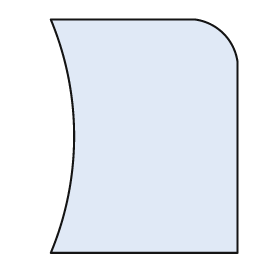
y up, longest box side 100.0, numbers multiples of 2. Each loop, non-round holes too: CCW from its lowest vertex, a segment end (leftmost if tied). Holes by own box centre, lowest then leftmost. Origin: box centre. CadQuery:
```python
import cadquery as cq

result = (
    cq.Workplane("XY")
    .moveTo(-40.0, -50.0)
    .lineTo(40.0, -50.0)
    .lineTo(40.0, 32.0)
    .threePointArc((34.0, 44.0), (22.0, 50.0))
    .lineTo(-40.0, 50.0)
    .threePointArc((-30.0, 0.0), (-40.0, -50.0))
    .close()
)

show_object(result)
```